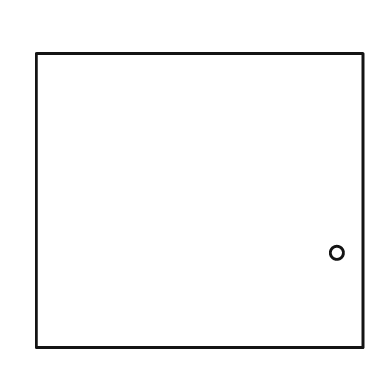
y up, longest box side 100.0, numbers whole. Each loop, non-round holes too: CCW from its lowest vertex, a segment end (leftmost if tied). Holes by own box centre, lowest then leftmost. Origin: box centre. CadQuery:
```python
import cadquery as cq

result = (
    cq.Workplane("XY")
    .moveTo(-50.0, -45.0)
    .lineTo(50.0, -45.0)
    .lineTo(50.0, 45.0)
    .lineTo(-50.0, 45.0)
    .close()
    .moveTo(42.0, -16.0)
    .circle(2.0)
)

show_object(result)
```